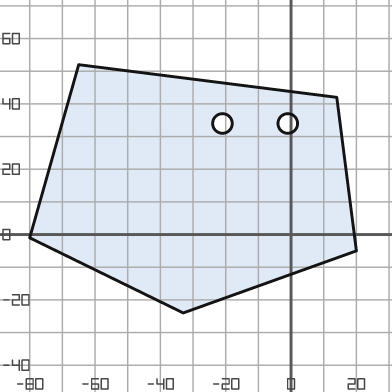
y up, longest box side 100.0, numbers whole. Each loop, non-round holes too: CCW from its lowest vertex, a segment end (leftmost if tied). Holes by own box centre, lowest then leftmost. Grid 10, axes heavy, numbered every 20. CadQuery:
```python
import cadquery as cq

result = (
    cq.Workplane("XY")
    .moveTo(-33.0, -24.0)
    .lineTo(20.0, -5.0)
    .lineTo(14.0, 42.0)
    .lineTo(-65.0, 52.0)
    .lineTo(-80.0, -1.0)
    .close()
    .moveTo(-21.0, 34.0)
    .circle(3.0)
    .moveTo(-1.0, 34.0)
    .circle(3.0)
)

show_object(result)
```